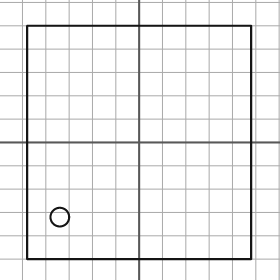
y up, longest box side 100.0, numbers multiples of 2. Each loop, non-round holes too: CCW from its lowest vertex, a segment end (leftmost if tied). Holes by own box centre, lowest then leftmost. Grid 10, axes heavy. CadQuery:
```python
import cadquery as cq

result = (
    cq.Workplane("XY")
    .moveTo(-48.0, -50.0)
    .lineTo(48.0, -50.0)
    .lineTo(48.0, 50.0)
    .lineTo(-48.0, 50.0)
    .close()
    .moveTo(-34.0, -32.0)
    .circle(4.0)
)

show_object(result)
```